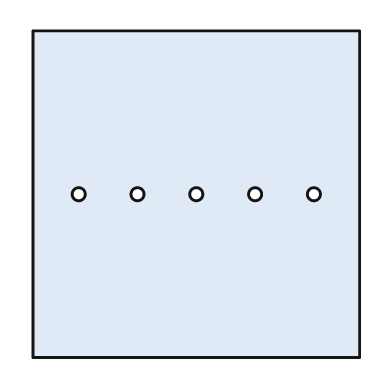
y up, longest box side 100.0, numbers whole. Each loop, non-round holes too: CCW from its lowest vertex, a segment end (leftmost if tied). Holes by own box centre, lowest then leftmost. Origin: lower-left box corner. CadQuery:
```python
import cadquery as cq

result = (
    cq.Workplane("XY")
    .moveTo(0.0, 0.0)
    .lineTo(100.0, 0.0)
    .lineTo(100.0, 100.0)
    .lineTo(0.0, 100.0)
    .close()
    .moveTo(14.0, 50.0)
    .circle(2.0)
    .moveTo(32.0, 50.0)
    .circle(2.0)
    .moveTo(50.0, 50.0)
    .circle(2.0)
    .moveTo(68.0, 50.0)
    .circle(2.0)
    .moveTo(86.0, 50.0)
    .circle(2.0)
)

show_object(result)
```